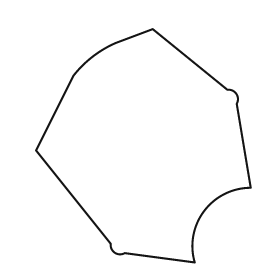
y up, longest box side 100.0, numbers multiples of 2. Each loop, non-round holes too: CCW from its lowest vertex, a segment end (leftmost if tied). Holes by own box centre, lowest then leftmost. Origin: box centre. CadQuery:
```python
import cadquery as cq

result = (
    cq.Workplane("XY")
    .moveTo(22.0, -50.0)
    .threePointArc((26.0, -28.0), (46.0, -18.0))
    .lineTo(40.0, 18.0)
    .threePointArc((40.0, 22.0), (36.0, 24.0))
    .lineTo(4.0, 50.0)
    .lineTo(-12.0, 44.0)
    .threePointArc((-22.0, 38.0), (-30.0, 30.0))
    .lineTo(-46.0, -2.0)
    .lineTo(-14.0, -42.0)
    .threePointArc((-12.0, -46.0), (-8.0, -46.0))
    .close()
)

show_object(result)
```